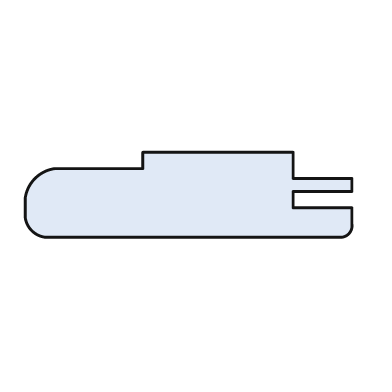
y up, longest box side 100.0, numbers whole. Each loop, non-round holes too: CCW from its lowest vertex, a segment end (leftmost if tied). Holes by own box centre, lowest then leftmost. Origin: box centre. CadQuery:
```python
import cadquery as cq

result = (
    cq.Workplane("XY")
    .moveTo(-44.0, -13.0)
    .lineTo(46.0, -13.0)
    .threePointArc((49.0, -12.0), (50.0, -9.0))
    .lineTo(50.0, -4.0)
    .lineTo(32.0, -4.0)
    .lineTo(32.0, 1.0)
    .lineTo(50.0, 1.0)
    .lineTo(50.0, 5.0)
    .lineTo(32.0, 5.0)
    .lineTo(32.0, 13.0)
    .lineTo(-14.0, 13.0)
    .lineTo(-14.0, 8.0)
    .lineTo(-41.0, 8.0)
    .threePointArc((-47.0, 5.0), (-50.0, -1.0))
    .lineTo(-50.0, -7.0)
    .threePointArc((-48.0, -11.0), (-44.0, -13.0))
    .close()
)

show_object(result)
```